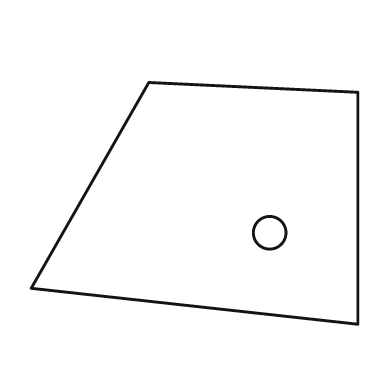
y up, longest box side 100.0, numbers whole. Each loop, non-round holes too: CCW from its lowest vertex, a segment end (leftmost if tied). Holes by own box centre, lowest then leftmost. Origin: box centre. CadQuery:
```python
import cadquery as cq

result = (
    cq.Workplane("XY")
    .moveTo(50.0, -37.0)
    .lineTo(50.0, 34.0)
    .lineTo(-14.0, 37.0)
    .lineTo(-50.0, -26.0)
    .close()
    .moveTo(23.0, -9.0)
    .circle(5.0)
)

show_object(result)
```